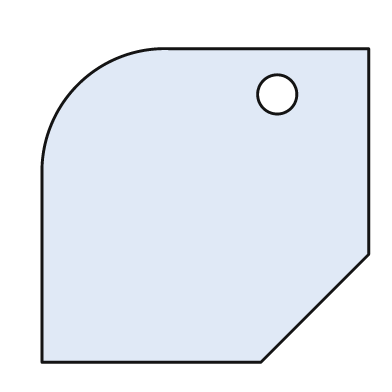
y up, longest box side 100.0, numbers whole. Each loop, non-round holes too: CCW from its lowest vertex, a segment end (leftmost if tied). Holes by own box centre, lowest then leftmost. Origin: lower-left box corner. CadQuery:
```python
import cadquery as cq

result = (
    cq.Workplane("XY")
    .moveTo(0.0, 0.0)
    .lineTo(67.0, 0.0)
    .lineTo(100.0, 33.0)
    .lineTo(100.0, 96.0)
    .lineTo(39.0, 96.0)
    .threePointArc((11.0, 85.0), (0.0, 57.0))
    .close()
    .moveTo(72.0, 82.0)
    .circle(6.0)
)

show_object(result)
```